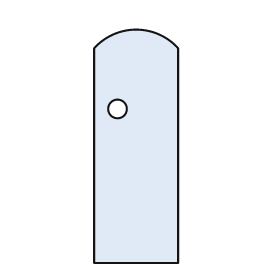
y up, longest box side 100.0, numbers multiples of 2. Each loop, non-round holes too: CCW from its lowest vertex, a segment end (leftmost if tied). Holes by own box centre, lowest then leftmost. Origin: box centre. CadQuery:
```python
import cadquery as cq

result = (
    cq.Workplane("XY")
    .moveTo(-18.0, -50.0)
    .lineTo(18.0, -50.0)
    .lineTo(18.0, 42.0)
    .threePointArc((0.0, 50.0), (-18.0, 42.0))
    .close()
    .moveTo(-8.0, 16.0)
    .circle(4.0)
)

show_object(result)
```